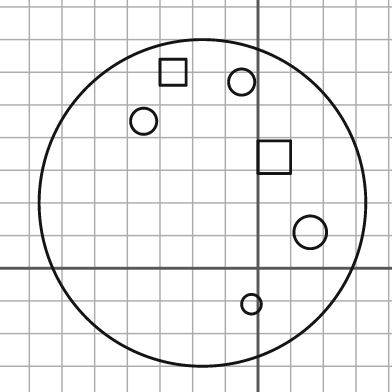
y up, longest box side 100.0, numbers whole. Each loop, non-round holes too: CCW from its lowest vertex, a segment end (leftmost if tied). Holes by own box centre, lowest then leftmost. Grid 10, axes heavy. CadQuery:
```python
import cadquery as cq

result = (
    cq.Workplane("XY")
    .moveTo(-17.0, 20.0)
    .circle(50.0)
    .moveTo(-2.0, -11.0)
    .circle(3.0)
    .moveTo(16.0, 11.0)
    .circle(5.0)
    .moveTo(0.0, 29.0)
    .lineTo(10.0, 29.0)
    .lineTo(10.0, 39.0)
    .lineTo(0.0, 39.0)
    .close()
    .moveTo(-35.0, 45.0)
    .circle(4.0)
    .moveTo(-5.0, 57.0)
    .circle(4.0)
    .moveTo(-30.0, 56.0)
    .lineTo(-22.0, 56.0)
    .lineTo(-22.0, 64.0)
    .lineTo(-30.0, 64.0)
    .close()
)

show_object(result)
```